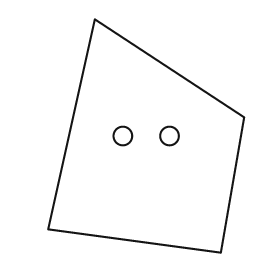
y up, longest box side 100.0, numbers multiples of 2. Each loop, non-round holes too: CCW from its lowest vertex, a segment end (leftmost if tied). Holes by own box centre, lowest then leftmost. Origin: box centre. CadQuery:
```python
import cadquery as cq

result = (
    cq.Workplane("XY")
    .moveTo(32.0, -50.0)
    .lineTo(42.0, 8.0)
    .lineTo(-22.0, 50.0)
    .lineTo(-42.0, -40.0)
    .close()
    .moveTo(-10.0, 0.0)
    .circle(4.0)
    .moveTo(10.0, 0.0)
    .circle(4.0)
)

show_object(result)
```